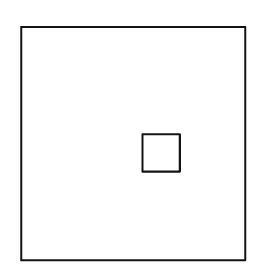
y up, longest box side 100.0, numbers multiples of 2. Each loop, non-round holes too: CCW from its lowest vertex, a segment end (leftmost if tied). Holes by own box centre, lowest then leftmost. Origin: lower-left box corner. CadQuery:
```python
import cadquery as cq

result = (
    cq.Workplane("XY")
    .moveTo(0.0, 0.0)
    .lineTo(96.0, 0.0)
    .lineTo(96.0, 100.0)
    .lineTo(0.0, 100.0)
    .close()
    .moveTo(52.0, 38.0)
    .lineTo(68.0, 38.0)
    .lineTo(68.0, 54.0)
    .lineTo(52.0, 54.0)
    .close()
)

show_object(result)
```